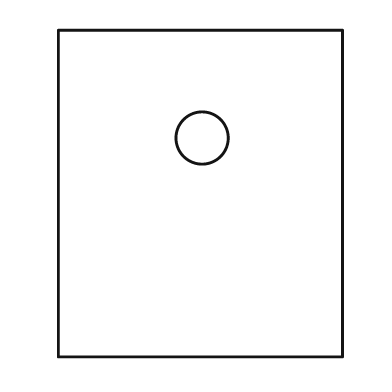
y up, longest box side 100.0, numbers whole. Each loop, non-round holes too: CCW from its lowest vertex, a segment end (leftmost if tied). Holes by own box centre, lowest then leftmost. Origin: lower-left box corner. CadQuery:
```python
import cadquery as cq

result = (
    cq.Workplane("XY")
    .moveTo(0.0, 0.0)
    .lineTo(87.0, 0.0)
    .lineTo(87.0, 100.0)
    .lineTo(0.0, 100.0)
    .close()
    .moveTo(44.0, 67.0)
    .circle(8.0)
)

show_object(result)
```